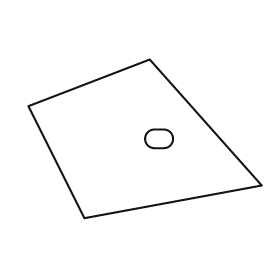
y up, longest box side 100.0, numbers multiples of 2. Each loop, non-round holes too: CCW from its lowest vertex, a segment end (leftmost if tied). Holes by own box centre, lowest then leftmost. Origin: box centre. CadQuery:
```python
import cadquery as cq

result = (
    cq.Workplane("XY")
    .moveTo(-26.0, -34.0)
    .lineTo(50.0, -20.0)
    .lineTo(2.0, 34.0)
    .lineTo(-50.0, 14.0)
    .close()
    .moveTo(4.0, -4.0)
    .lineTo(8.0, -4.0)
    .threePointArc((12.0, 0.0), (8.0, 4.0))
    .lineTo(4.0, 4.0)
    .threePointArc((0.0, 0.0), (4.0, -4.0))
    .close()
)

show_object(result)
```